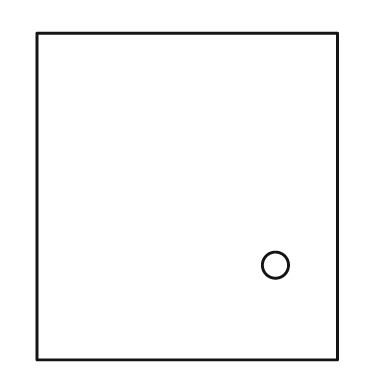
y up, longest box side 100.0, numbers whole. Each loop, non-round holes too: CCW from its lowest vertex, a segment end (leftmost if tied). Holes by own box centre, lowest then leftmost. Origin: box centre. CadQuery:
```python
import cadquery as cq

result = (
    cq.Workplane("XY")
    .moveTo(-46.0, -50.0)
    .lineTo(46.0, -50.0)
    .lineTo(46.0, 50.0)
    .lineTo(-46.0, 50.0)
    .close()
    .moveTo(27.0, -21.0)
    .circle(4.0)
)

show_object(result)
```